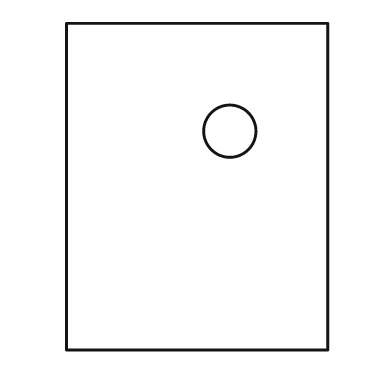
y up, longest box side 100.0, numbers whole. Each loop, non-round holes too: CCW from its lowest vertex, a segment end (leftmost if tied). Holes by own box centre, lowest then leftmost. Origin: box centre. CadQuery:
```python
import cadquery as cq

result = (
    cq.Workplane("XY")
    .moveTo(-40.0, -50.0)
    .lineTo(40.0, -50.0)
    .lineTo(40.0, 50.0)
    .lineTo(-40.0, 50.0)
    .close()
    .moveTo(10.0, 17.0)
    .circle(8.0)
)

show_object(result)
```